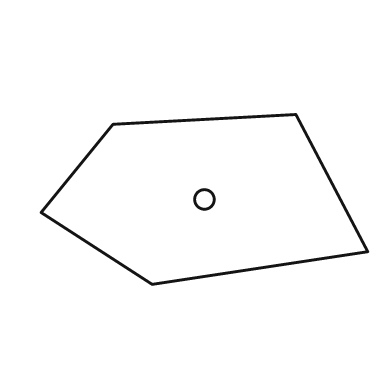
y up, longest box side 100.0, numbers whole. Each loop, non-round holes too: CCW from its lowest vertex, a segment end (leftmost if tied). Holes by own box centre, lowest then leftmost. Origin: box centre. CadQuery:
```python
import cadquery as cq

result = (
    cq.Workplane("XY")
    .moveTo(-16.0, -26.0)
    .lineTo(50.0, -16.0)
    .lineTo(28.0, 26.0)
    .lineTo(-28.0, 23.0)
    .lineTo(-50.0, -4.0)
    .close()
    .moveTo(0.0, 0.0)
    .circle(3.0)
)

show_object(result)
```